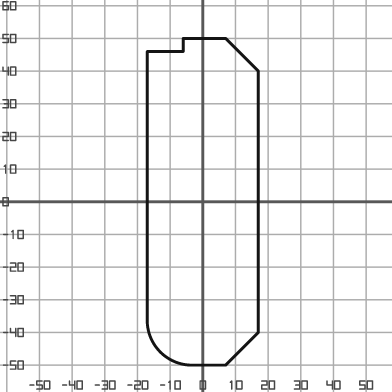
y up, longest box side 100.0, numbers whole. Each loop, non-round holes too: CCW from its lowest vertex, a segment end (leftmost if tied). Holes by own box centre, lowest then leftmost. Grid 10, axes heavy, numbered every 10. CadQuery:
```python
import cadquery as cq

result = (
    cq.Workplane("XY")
    .moveTo(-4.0, -50.0)
    .lineTo(7.0, -50.0)
    .lineTo(17.0, -40.0)
    .lineTo(17.0, 40.0)
    .lineTo(7.0, 50.0)
    .lineTo(-6.0, 50.0)
    .lineTo(-6.0, 46.0)
    .lineTo(-17.0, 46.0)
    .lineTo(-17.0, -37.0)
    .threePointArc((-13.0, -46.0), (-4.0, -50.0))
    .close()
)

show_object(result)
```